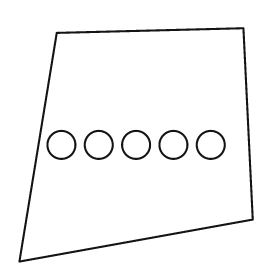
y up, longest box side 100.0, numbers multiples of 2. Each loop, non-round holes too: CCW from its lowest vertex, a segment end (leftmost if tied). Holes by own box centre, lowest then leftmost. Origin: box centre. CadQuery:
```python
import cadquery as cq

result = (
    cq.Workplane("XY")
    .moveTo(-50.0, -50.0)
    .lineTo(50.0, -32.0)
    .lineTo(46.0, 50.0)
    .lineTo(-34.0, 48.0)
    .close()
    .moveTo(-32.0, 0.0)
    .circle(6.0)
    .moveTo(-16.0, 0.0)
    .circle(6.0)
    .moveTo(0.0, 0.0)
    .circle(6.0)
    .moveTo(16.0, 0.0)
    .circle(6.0)
    .moveTo(32.0, 0.0)
    .circle(6.0)
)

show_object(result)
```